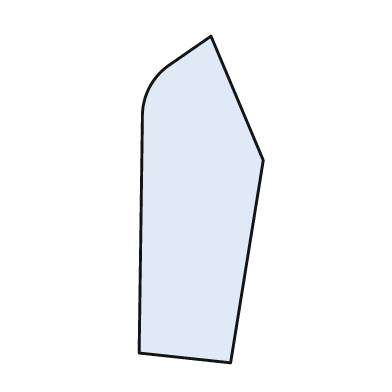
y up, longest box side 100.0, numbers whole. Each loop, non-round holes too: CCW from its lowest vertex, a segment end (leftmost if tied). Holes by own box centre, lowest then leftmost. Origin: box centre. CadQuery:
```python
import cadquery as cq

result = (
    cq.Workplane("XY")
    .moveTo(9.0, -50.0)
    .lineTo(19.0, 12.0)
    .lineTo(3.0, 50.0)
    .lineTo(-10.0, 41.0)
    .threePointArc((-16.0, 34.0), (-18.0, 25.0))
    .lineTo(-19.0, -47.0)
    .close()
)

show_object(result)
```